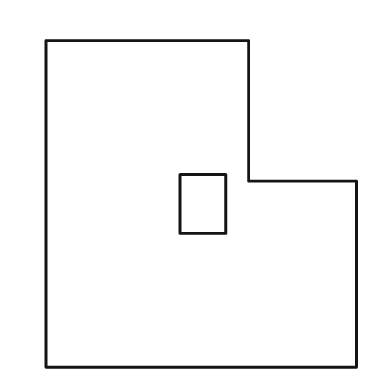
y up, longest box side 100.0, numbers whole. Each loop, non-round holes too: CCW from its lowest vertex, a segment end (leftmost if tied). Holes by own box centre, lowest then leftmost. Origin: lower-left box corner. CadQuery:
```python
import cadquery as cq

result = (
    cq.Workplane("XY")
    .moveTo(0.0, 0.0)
    .lineTo(95.0, 0.0)
    .lineTo(95.0, 57.0)
    .lineTo(62.0, 57.0)
    .lineTo(62.0, 100.0)
    .lineTo(0.0, 100.0)
    .close()
    .moveTo(41.0, 41.0)
    .lineTo(55.0, 41.0)
    .lineTo(55.0, 59.0)
    .lineTo(41.0, 59.0)
    .close()
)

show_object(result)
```